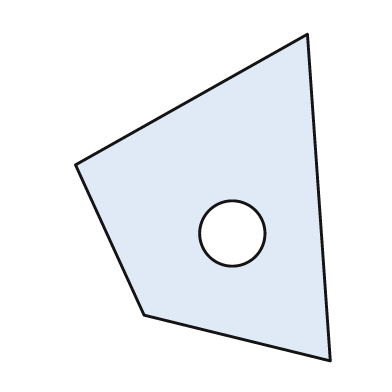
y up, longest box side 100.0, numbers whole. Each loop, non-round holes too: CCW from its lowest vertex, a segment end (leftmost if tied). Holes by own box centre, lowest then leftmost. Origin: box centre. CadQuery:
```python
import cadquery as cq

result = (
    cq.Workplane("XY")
    .moveTo(39.0, -50.0)
    .lineTo(32.0, 50.0)
    .lineTo(-39.0, 10.0)
    .lineTo(-18.0, -36.0)
    .close()
    .moveTo(9.0, -11.0)
    .circle(10.0)
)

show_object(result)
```